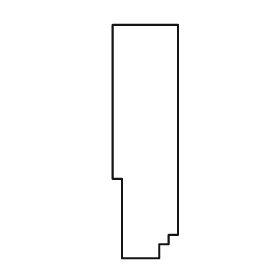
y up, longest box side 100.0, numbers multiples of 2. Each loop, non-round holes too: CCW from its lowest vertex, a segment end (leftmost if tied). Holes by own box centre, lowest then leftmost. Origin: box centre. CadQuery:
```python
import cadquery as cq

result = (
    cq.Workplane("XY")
    .moveTo(-10.0, -50.0)
    .lineTo(6.0, -50.0)
    .lineTo(6.0, -44.0)
    .lineTo(10.0, -44.0)
    .lineTo(10.0, -40.0)
    .lineTo(14.0, -40.0)
    .lineTo(14.0, 50.0)
    .lineTo(-14.0, 50.0)
    .lineTo(-14.0, -16.0)
    .lineTo(-10.0, -16.0)
    .close()
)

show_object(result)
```